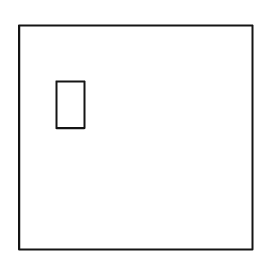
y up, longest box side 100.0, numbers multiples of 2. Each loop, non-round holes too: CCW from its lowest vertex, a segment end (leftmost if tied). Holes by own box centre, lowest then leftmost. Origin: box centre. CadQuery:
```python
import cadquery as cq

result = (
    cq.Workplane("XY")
    .moveTo(-50.0, -48.0)
    .lineTo(50.0, -48.0)
    .lineTo(50.0, 48.0)
    .lineTo(-50.0, 48.0)
    .close()
    .moveTo(-34.0, 4.0)
    .lineTo(-22.0, 4.0)
    .lineTo(-22.0, 24.0)
    .lineTo(-34.0, 24.0)
    .close()
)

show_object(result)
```